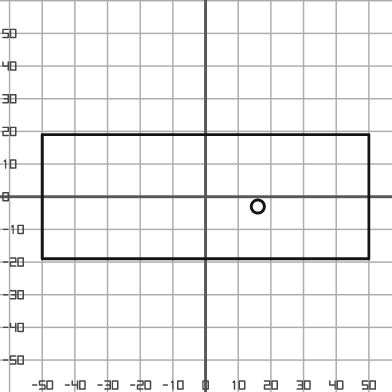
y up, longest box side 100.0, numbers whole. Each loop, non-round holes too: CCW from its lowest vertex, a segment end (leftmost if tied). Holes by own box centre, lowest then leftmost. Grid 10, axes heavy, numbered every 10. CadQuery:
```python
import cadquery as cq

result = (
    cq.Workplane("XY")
    .moveTo(-50.0, -19.0)
    .lineTo(50.0, -19.0)
    .lineTo(50.0, 19.0)
    .lineTo(-50.0, 19.0)
    .close()
    .moveTo(16.0, -3.0)
    .circle(2.0)
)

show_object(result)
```